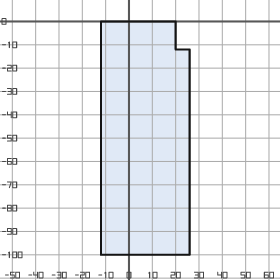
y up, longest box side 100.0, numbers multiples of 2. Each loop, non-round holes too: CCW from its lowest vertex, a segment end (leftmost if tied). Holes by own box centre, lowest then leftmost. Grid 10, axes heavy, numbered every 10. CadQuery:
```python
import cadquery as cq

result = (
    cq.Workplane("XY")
    .moveTo(-12.0, -100.0)
    .lineTo(26.0, -100.0)
    .lineTo(26.0, -12.0)
    .lineTo(20.0, -12.0)
    .lineTo(20.0, 0.0)
    .lineTo(-12.0, 0.0)
    .close()
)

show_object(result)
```